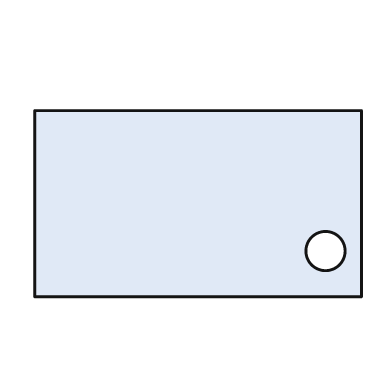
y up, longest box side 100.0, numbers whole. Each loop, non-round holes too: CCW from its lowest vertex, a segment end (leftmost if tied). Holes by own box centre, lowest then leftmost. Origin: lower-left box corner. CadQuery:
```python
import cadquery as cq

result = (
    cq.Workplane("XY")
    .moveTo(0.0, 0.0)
    .lineTo(100.0, 0.0)
    .lineTo(100.0, 57.0)
    .lineTo(0.0, 57.0)
    .close()
    .moveTo(89.0, 14.0)
    .circle(6.0)
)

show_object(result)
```